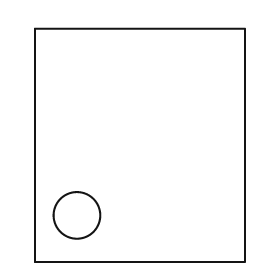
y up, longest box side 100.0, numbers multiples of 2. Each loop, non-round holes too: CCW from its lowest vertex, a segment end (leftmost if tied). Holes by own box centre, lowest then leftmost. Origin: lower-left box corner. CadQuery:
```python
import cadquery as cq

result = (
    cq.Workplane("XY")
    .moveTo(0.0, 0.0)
    .lineTo(90.0, 0.0)
    .lineTo(90.0, 100.0)
    .lineTo(0.0, 100.0)
    .close()
    .moveTo(18.0, 20.0)
    .circle(10.0)
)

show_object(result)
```